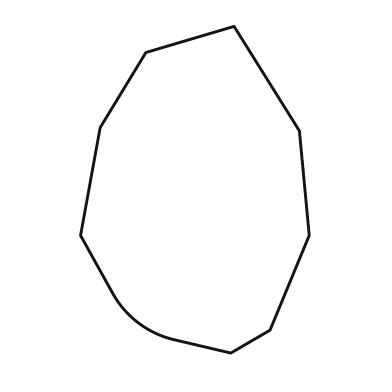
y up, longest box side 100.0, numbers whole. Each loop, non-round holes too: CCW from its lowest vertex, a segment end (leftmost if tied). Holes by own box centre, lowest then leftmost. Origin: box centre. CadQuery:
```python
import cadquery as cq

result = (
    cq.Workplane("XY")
    .moveTo(11.0, -50.0)
    .lineTo(23.0, -43.0)
    .lineTo(35.0, -14.0)
    .lineTo(32.0, 18.0)
    .lineTo(12.0, 50.0)
    .lineTo(-15.0, 42.0)
    .lineTo(-29.0, 19.0)
    .lineTo(-35.0, -14.0)
    .lineTo(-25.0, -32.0)
    .threePointArc((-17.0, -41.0), (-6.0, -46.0))
    .close()
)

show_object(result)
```